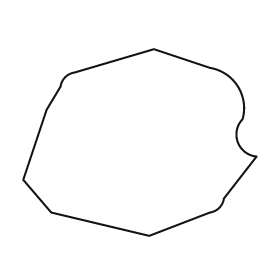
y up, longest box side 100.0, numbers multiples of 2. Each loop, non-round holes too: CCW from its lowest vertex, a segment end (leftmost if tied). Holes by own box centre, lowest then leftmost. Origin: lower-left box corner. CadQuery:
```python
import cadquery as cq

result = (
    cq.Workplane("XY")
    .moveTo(54.0, 0.0)
    .lineTo(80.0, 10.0)
    .threePointArc((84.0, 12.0), (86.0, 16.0))
    .lineTo(100.0, 34.0)
    .threePointArc((92.0, 40.0), (94.0, 50.0))
    .threePointArc((92.0, 64.0), (80.0, 72.0))
    .lineTo(56.0, 80.0)
    .lineTo(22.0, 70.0)
    .threePointArc((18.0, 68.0), (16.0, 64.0))
    .lineTo(10.0, 54.0)
    .lineTo(0.0, 24.0)
    .lineTo(12.0, 10.0)
    .close()
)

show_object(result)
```